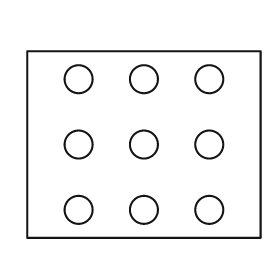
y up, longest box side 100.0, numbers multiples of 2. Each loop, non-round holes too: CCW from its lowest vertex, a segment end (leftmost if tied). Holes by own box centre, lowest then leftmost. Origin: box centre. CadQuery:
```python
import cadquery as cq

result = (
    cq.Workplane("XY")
    .moveTo(-50.0, -40.0)
    .lineTo(50.0, -40.0)
    .lineTo(50.0, 40.0)
    .lineTo(-50.0, 40.0)
    .close()
    .moveTo(-28.0, -28.0)
    .circle(6.0)
    .moveTo(0.0, -28.0)
    .circle(6.0)
    .moveTo(28.0, -28.0)
    .circle(6.0)
    .moveTo(-28.0, 0.0)
    .circle(6.0)
    .moveTo(0.0, 0.0)
    .circle(6.0)
    .moveTo(28.0, 0.0)
    .circle(6.0)
    .moveTo(-28.0, 28.0)
    .circle(6.0)
    .moveTo(0.0, 28.0)
    .circle(6.0)
    .moveTo(28.0, 28.0)
    .circle(6.0)
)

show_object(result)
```